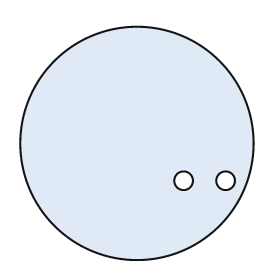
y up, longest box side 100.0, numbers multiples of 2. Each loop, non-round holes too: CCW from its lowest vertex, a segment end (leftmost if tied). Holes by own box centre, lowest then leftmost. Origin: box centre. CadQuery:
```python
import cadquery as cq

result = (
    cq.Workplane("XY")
    .moveTo(0.0, 0.0)
    .circle(50.0)
    .moveTo(20.0, -16.0)
    .circle(4.0)
    .moveTo(38.0, -16.0)
    .circle(4.0)
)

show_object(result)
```